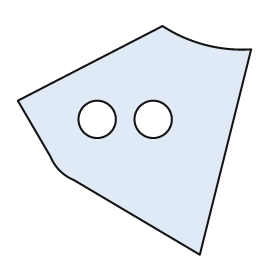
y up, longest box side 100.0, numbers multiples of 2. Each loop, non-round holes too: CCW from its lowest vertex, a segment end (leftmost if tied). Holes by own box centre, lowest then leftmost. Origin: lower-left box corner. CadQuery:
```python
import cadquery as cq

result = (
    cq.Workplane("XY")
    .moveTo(78.0, 0.0)
    .lineTo(100.0, 88.0)
    .threePointArc((80.0, 90.0), (62.0, 98.0))
    .lineTo(0.0, 66.0)
    .lineTo(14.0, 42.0)
    .threePointArc((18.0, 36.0), (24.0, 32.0))
    .close()
    .moveTo(34.0, 58.0)
    .circle(8.0)
    .moveTo(58.0, 58.0)
    .circle(8.0)
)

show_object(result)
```